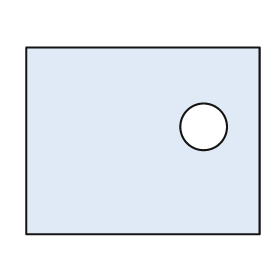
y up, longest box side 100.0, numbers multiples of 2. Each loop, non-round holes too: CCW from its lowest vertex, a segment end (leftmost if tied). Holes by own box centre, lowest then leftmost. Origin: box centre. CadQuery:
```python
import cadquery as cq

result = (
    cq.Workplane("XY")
    .moveTo(-50.0, -40.0)
    .lineTo(50.0, -40.0)
    .lineTo(50.0, 40.0)
    .lineTo(-50.0, 40.0)
    .close()
    .moveTo(26.0, 6.0)
    .circle(10.0)
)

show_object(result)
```